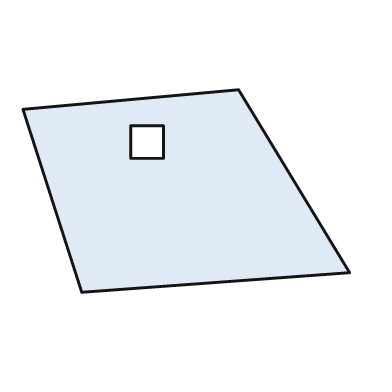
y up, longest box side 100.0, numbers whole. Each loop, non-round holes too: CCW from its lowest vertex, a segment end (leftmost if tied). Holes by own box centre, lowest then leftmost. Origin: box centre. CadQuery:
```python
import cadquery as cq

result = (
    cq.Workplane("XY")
    .moveTo(-32.0, -31.0)
    .lineTo(50.0, -25.0)
    .lineTo(16.0, 31.0)
    .lineTo(-50.0, 25.0)
    .close()
    .moveTo(-17.0, 10.0)
    .lineTo(-7.0, 10.0)
    .lineTo(-7.0, 20.0)
    .lineTo(-17.0, 20.0)
    .close()
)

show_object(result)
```